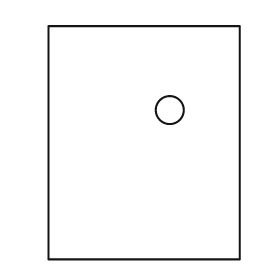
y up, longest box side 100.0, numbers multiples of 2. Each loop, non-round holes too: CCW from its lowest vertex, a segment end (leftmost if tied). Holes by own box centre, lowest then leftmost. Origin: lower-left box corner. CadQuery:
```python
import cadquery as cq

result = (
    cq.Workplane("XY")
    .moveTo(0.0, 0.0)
    .lineTo(82.0, 0.0)
    .lineTo(82.0, 100.0)
    .lineTo(0.0, 100.0)
    .close()
    .moveTo(52.0, 64.0)
    .circle(6.0)
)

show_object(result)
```